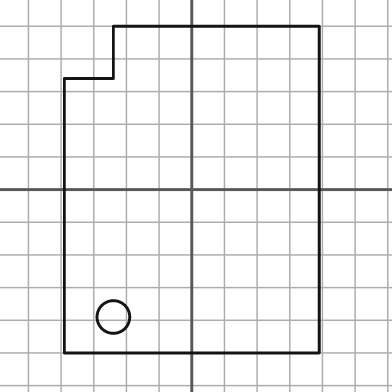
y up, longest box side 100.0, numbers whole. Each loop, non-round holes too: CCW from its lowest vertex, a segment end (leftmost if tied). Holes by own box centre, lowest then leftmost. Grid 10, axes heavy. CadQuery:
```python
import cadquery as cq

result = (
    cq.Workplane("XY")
    .moveTo(-39.0, -50.0)
    .lineTo(39.0, -50.0)
    .lineTo(39.0, 50.0)
    .lineTo(-24.0, 50.0)
    .lineTo(-24.0, 34.0)
    .lineTo(-39.0, 34.0)
    .close()
    .moveTo(-24.0, -39.0)
    .circle(5.0)
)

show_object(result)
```